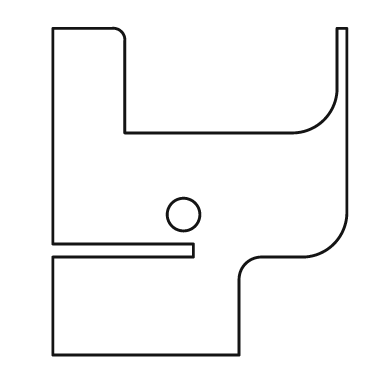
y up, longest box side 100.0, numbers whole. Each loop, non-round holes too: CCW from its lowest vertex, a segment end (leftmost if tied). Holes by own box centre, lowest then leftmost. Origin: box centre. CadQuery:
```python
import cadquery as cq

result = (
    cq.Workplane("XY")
    .moveTo(-45.0, -50.0)
    .lineTo(12.0, -50.0)
    .lineTo(12.0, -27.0)
    .threePointArc((14.0, -22.0), (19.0, -20.0))
    .lineTo(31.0, -20.0)
    .threePointArc((41.0, -16.0), (45.0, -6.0))
    .lineTo(45.0, 50.0)
    .lineTo(42.0, 50.0)
    .lineTo(42.0, 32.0)
    .threePointArc((38.0, 22.0), (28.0, 18.0))
    .lineTo(-23.0, 18.0)
    .lineTo(-23.0, 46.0)
    .threePointArc((-24.0, 49.0), (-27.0, 50.0))
    .lineTo(-45.0, 50.0)
    .lineTo(-45.0, -16.0)
    .lineTo(-2.0, -16.0)
    .lineTo(-2.0, -20.0)
    .lineTo(-45.0, -20.0)
    .close()
    .moveTo(-5.0, -7.0)
    .circle(5.0)
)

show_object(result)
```